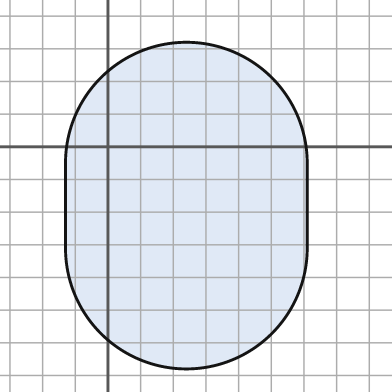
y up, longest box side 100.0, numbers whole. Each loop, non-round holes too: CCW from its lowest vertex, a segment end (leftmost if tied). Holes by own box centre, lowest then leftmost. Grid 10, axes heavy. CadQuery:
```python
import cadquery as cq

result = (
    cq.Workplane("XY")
    .moveTo(-13.0, -31.0)
    .threePointArc((24.0, -68.0), (61.0, -31.0))
    .lineTo(61.0, -5.0)
    .threePointArc((24.0, 32.0), (-13.0, -5.0))
    .close()
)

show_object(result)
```